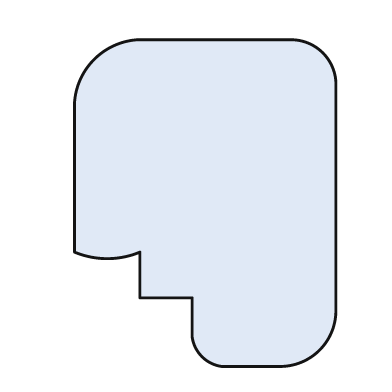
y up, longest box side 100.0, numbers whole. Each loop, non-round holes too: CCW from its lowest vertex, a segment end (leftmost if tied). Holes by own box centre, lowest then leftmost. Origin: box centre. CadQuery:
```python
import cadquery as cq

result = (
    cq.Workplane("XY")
    .moveTo(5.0, -50.0)
    .lineTo(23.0, -50.0)
    .threePointArc((35.0, -45.0), (40.0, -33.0))
    .lineTo(40.0, 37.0)
    .threePointArc((36.0, 46.0), (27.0, 50.0))
    .lineTo(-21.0, 50.0)
    .threePointArc((-34.0, 44.0), (-40.0, 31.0))
    .lineTo(-40.0, -15.0)
    .threePointArc((-30.0, -17.0), (-20.0, -15.0))
    .lineTo(-20.0, -29.0)
    .lineTo(-4.0, -29.0)
    .lineTo(-4.0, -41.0)
    .threePointArc((-1.0, -47.0), (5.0, -50.0))
    .close()
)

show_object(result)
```